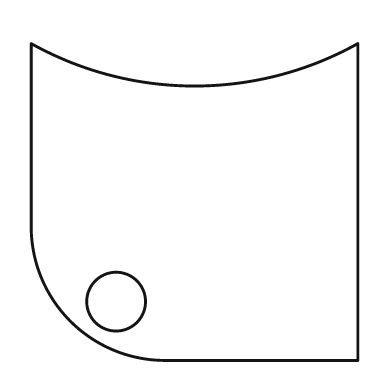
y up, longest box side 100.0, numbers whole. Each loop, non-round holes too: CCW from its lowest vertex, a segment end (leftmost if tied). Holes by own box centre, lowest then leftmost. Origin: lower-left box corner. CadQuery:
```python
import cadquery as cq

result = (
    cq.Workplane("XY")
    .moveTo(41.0, 0.0)
    .lineTo(100.0, 0.0)
    .lineTo(100.0, 97.0)
    .threePointArc((50.0, 84.0), (0.0, 97.0))
    .lineTo(0.0, 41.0)
    .threePointArc((12.0, 12.0), (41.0, 0.0))
    .close()
    .moveTo(26.0, 18.0)
    .circle(9.0)
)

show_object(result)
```